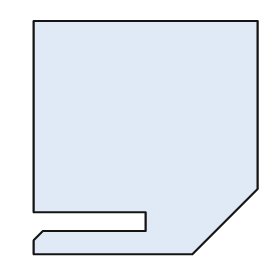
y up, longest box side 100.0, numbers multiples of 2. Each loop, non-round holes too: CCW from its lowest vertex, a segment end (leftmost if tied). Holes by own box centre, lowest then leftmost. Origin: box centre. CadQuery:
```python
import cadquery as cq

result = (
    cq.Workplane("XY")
    .moveTo(-48.0, -50.0)
    .lineTo(20.0, -50.0)
    .lineTo(48.0, -22.0)
    .lineTo(48.0, 50.0)
    .lineTo(-48.0, 50.0)
    .lineTo(-48.0, -32.0)
    .lineTo(0.0, -32.0)
    .lineTo(0.0, -40.0)
    .lineTo(-44.0, -40.0)
    .lineTo(-48.0, -44.0)
    .close()
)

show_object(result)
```